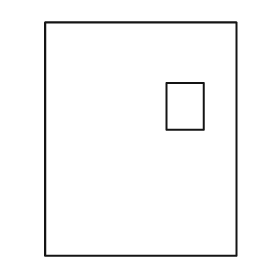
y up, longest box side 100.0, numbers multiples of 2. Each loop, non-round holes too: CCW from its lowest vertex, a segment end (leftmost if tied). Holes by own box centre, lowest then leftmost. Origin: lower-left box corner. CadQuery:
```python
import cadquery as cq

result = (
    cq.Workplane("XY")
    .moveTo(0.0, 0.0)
    .lineTo(82.0, 0.0)
    .lineTo(82.0, 100.0)
    .lineTo(0.0, 100.0)
    .close()
    .moveTo(52.0, 54.0)
    .lineTo(68.0, 54.0)
    .lineTo(68.0, 74.0)
    .lineTo(52.0, 74.0)
    .close()
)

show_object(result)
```